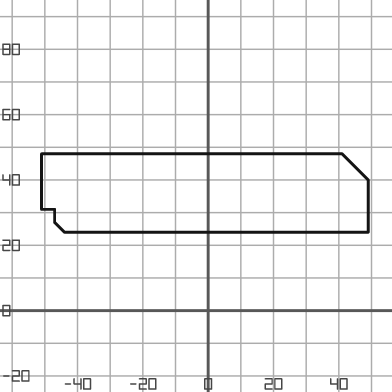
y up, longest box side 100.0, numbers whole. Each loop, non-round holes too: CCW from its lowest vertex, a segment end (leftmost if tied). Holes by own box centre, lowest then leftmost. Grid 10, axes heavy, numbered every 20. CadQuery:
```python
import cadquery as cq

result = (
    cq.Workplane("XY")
    .moveTo(-44.0, 24.0)
    .lineTo(49.0, 24.0)
    .lineTo(49.0, 40.0)
    .lineTo(41.0, 48.0)
    .lineTo(-51.0, 48.0)
    .lineTo(-51.0, 31.0)
    .lineTo(-47.0, 31.0)
    .lineTo(-47.0, 27.0)
    .close()
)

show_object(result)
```